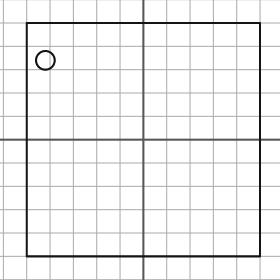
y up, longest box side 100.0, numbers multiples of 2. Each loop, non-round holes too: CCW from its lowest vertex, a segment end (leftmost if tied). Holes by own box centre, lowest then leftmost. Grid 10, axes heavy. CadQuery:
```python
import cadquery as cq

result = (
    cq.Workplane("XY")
    .moveTo(-50.0, -50.0)
    .lineTo(50.0, -50.0)
    .lineTo(50.0, 50.0)
    .lineTo(-50.0, 50.0)
    .close()
    .moveTo(-42.0, 34.0)
    .circle(4.0)
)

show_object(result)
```